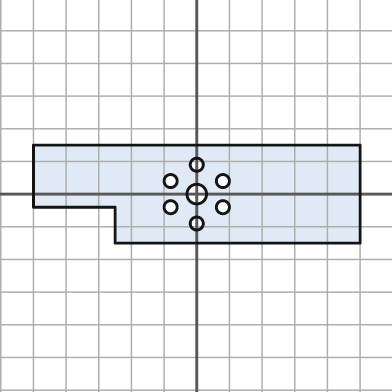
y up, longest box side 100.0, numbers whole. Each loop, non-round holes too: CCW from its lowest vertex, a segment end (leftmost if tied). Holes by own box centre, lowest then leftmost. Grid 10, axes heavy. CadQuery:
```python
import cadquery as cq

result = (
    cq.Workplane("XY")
    .moveTo(-25.0, -15.0)
    .lineTo(50.0, -15.0)
    .lineTo(50.0, 15.0)
    .lineTo(-50.0, 15.0)
    .lineTo(-50.0, -4.0)
    .lineTo(-25.0, -4.0)
    .close()
    .moveTo(0.0, -9.0)
    .circle(2.0)
    .moveTo(-8.0, -4.0)
    .circle(2.0)
    .moveTo(8.0, -4.0)
    .circle(2.0)
    .moveTo(0.0, 0.0)
    .circle(3.0)
    .moveTo(-8.0, 4.0)
    .circle(2.0)
    .moveTo(8.0, 4.0)
    .circle(2.0)
    .moveTo(0.0, 9.0)
    .circle(2.0)
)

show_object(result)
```